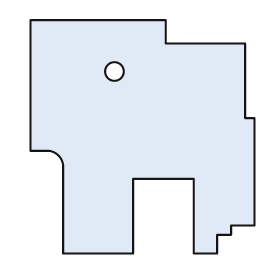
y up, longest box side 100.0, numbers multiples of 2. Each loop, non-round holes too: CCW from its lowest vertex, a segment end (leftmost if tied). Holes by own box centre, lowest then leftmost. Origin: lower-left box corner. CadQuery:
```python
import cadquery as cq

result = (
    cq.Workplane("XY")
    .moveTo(14.0, 0.0)
    .lineTo(44.0, 0.0)
    .lineTo(44.0, 32.0)
    .lineTo(70.0, 32.0)
    .lineTo(70.0, 0.0)
    .lineTo(80.0, 0.0)
    .lineTo(80.0, 8.0)
    .lineTo(86.0, 8.0)
    .lineTo(86.0, 12.0)
    .lineTo(96.0, 12.0)
    .lineTo(96.0, 58.0)
    .lineTo(92.0, 58.0)
    .lineTo(92.0, 90.0)
    .lineTo(58.0, 90.0)
    .lineTo(58.0, 100.0)
    .lineTo(0.0, 100.0)
    .lineTo(0.0, 44.0)
    .lineTo(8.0, 44.0)
    .threePointArc((12.0, 42.0), (14.0, 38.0))
    .close()
    .moveTo(36.0, 78.0)
    .circle(4.0)
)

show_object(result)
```